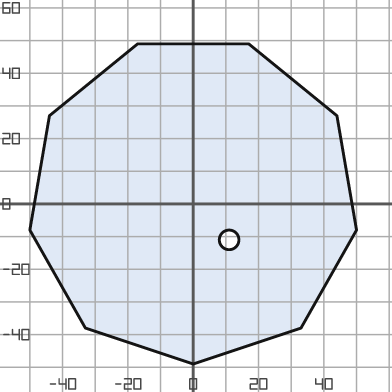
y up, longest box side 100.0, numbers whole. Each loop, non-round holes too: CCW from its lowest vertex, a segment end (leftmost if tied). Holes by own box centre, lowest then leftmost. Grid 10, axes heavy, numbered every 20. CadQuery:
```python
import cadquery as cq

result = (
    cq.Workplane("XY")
    .moveTo(0.0, -49.0)
    .lineTo(33.0, -38.0)
    .lineTo(50.0, -8.0)
    .lineTo(44.0, 27.0)
    .lineTo(17.0, 49.0)
    .lineTo(-17.0, 49.0)
    .lineTo(-44.0, 27.0)
    .lineTo(-50.0, -8.0)
    .lineTo(-33.0, -38.0)
    .close()
    .moveTo(11.0, -11.0)
    .circle(3.0)
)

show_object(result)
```